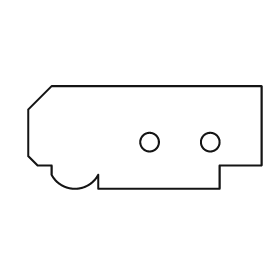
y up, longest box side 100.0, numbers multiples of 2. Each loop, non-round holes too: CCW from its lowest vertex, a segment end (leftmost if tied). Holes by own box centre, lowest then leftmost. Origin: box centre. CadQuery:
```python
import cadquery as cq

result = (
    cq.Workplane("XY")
    .moveTo(-20.0, -22.0)
    .lineTo(32.0, -22.0)
    .lineTo(32.0, -12.0)
    .lineTo(50.0, -12.0)
    .lineTo(50.0, 22.0)
    .lineTo(-40.0, 22.0)
    .lineTo(-50.0, 12.0)
    .lineTo(-50.0, -8.0)
    .lineTo(-46.0, -12.0)
    .lineTo(-40.0, -12.0)
    .lineTo(-40.0, -16.0)
    .threePointArc((-30.0, -22.0), (-20.0, -16.0))
    .close()
    .moveTo(2.0, -2.0)
    .circle(4.0)
    .moveTo(28.0, -2.0)
    .circle(4.0)
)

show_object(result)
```